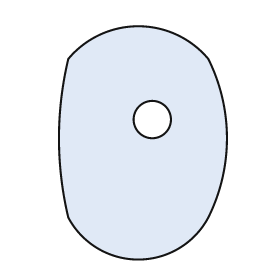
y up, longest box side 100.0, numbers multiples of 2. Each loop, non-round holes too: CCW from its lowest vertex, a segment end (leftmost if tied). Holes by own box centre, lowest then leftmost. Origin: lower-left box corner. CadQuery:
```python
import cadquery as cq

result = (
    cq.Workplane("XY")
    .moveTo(4.0, 18.0)
    .threePointArc((34.0, 0.0), (64.0, 18.0))
    .threePointArc((72.0, 52.0), (64.0, 86.0))
    .threePointArc((34.0, 100.0), (4.0, 86.0))
    .threePointArc((0.0, 52.0), (4.0, 18.0))
    .close()
    .moveTo(40.0, 60.0)
    .circle(8.0)
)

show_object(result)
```